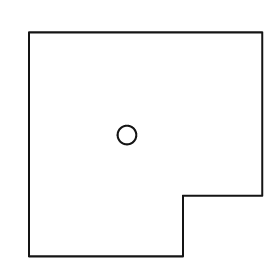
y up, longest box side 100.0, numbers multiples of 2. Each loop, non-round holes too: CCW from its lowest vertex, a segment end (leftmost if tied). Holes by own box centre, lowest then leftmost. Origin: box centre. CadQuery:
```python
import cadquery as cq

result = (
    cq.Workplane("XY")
    .moveTo(-50.0, -48.0)
    .lineTo(16.0, -48.0)
    .lineTo(16.0, -22.0)
    .lineTo(50.0, -22.0)
    .lineTo(50.0, 48.0)
    .lineTo(-50.0, 48.0)
    .close()
    .moveTo(-8.0, 4.0)
    .circle(4.0)
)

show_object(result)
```